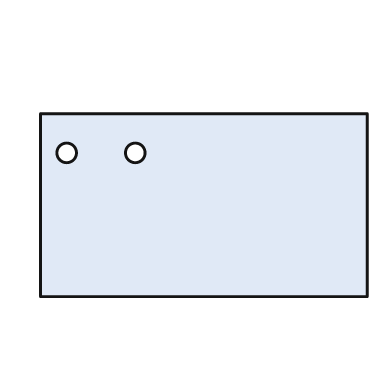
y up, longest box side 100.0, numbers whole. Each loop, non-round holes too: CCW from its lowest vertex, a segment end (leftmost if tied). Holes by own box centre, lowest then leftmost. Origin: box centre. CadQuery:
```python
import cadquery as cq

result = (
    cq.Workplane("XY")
    .moveTo(-50.0, -28.0)
    .lineTo(50.0, -28.0)
    .lineTo(50.0, 28.0)
    .lineTo(-50.0, 28.0)
    .close()
    .moveTo(-42.0, 16.0)
    .circle(3.0)
    .moveTo(-21.0, 16.0)
    .circle(3.0)
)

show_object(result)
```